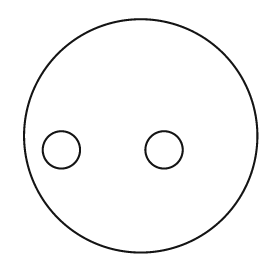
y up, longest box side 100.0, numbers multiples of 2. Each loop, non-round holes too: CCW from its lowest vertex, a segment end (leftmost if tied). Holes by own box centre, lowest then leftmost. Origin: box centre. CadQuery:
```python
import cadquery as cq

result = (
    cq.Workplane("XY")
    .moveTo(0.0, 0.0)
    .circle(50.0)
    .moveTo(-34.0, -6.0)
    .circle(8.0)
    .moveTo(10.0, -6.0)
    .circle(8.0)
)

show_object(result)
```